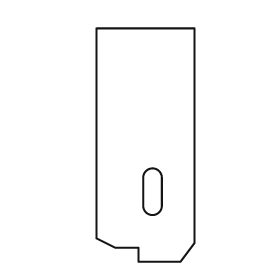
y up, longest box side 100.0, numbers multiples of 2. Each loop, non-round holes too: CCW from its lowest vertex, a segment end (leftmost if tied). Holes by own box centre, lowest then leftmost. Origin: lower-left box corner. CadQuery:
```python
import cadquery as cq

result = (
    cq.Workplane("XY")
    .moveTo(18.0, 0.0)
    .lineTo(36.0, 0.0)
    .lineTo(42.0, 8.0)
    .lineTo(42.0, 100.0)
    .lineTo(0.0, 100.0)
    .lineTo(0.0, 10.0)
    .lineTo(8.0, 6.0)
    .lineTo(18.0, 6.0)
    .close()
    .moveTo(20.0, 24.0)
    .threePointArc((24.0, 20.0), (28.0, 24.0))
    .lineTo(28.0, 36.0)
    .threePointArc((24.0, 40.0), (20.0, 36.0))
    .close()
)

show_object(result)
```